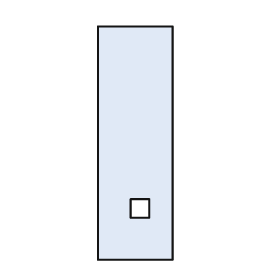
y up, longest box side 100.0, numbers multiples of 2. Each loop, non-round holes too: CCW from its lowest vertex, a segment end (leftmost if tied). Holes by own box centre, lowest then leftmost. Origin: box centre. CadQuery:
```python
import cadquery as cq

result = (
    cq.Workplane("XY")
    .moveTo(-16.0, -50.0)
    .lineTo(16.0, -50.0)
    .lineTo(16.0, 50.0)
    .lineTo(-16.0, 50.0)
    .close()
    .moveTo(-2.0, -32.0)
    .lineTo(6.0, -32.0)
    .lineTo(6.0, -24.0)
    .lineTo(-2.0, -24.0)
    .close()
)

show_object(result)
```